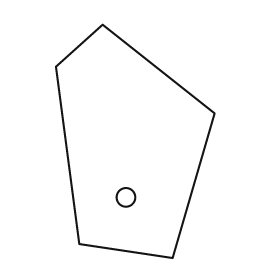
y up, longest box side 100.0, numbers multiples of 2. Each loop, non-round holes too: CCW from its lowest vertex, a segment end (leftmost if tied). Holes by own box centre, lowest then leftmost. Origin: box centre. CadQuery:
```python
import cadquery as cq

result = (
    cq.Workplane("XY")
    .moveTo(16.0, -50.0)
    .lineTo(34.0, 12.0)
    .lineTo(-14.0, 50.0)
    .lineTo(-34.0, 32.0)
    .lineTo(-24.0, -44.0)
    .close()
    .moveTo(-4.0, -24.0)
    .circle(4.0)
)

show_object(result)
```